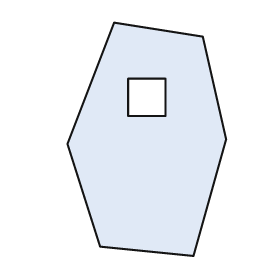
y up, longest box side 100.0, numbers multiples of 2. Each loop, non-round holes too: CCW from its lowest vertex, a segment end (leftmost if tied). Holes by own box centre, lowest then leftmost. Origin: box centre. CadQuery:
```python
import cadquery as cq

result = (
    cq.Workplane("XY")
    .moveTo(20.0, -50.0)
    .lineTo(34.0, 0.0)
    .lineTo(24.0, 44.0)
    .lineTo(-14.0, 50.0)
    .lineTo(-34.0, -2.0)
    .lineTo(-20.0, -46.0)
    .close()
    .moveTo(-8.0, 10.0)
    .lineTo(8.0, 10.0)
    .lineTo(8.0, 26.0)
    .lineTo(-8.0, 26.0)
    .close()
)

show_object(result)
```